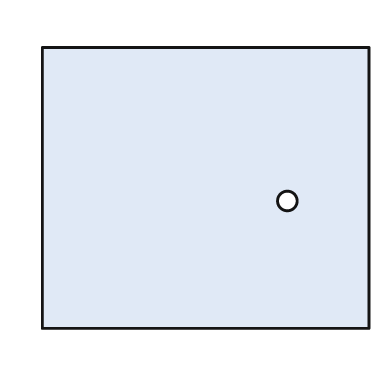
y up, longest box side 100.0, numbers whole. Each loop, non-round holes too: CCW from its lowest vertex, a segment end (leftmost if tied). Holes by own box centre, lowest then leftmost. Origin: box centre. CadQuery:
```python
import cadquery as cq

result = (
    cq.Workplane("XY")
    .moveTo(-50.0, -43.0)
    .lineTo(50.0, -43.0)
    .lineTo(50.0, 43.0)
    .lineTo(-50.0, 43.0)
    .close()
    .moveTo(25.0, -4.0)
    .circle(3.0)
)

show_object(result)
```